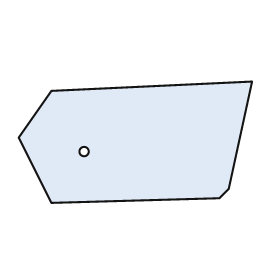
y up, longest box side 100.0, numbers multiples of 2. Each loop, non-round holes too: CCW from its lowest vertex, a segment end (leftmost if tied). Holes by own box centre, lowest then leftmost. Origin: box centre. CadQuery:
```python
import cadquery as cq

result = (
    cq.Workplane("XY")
    .moveTo(-36.0, -26.0)
    .lineTo(36.0, -24.0)
    .lineTo(40.0, -20.0)
    .lineTo(50.0, 26.0)
    .lineTo(-36.0, 22.0)
    .lineTo(-50.0, 2.0)
    .close()
    .moveTo(-22.0, -4.0)
    .circle(2.0)
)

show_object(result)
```